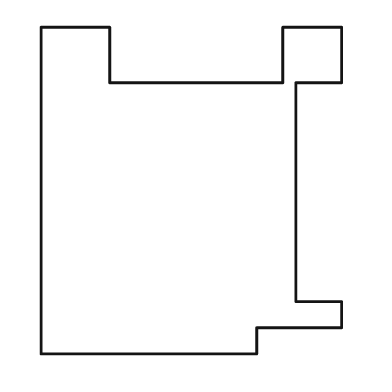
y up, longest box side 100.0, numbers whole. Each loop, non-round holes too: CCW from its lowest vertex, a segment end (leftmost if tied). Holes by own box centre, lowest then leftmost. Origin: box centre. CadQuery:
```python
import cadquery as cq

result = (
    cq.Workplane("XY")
    .moveTo(-46.0, -50.0)
    .lineTo(20.0, -50.0)
    .lineTo(20.0, -42.0)
    .lineTo(46.0, -42.0)
    .lineTo(46.0, -34.0)
    .lineTo(32.0, -34.0)
    .lineTo(32.0, 33.0)
    .lineTo(46.0, 33.0)
    .lineTo(46.0, 50.0)
    .lineTo(28.0, 50.0)
    .lineTo(28.0, 33.0)
    .lineTo(-25.0, 33.0)
    .lineTo(-25.0, 50.0)
    .lineTo(-46.0, 50.0)
    .close()
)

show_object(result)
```